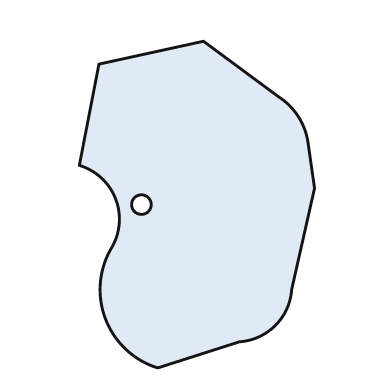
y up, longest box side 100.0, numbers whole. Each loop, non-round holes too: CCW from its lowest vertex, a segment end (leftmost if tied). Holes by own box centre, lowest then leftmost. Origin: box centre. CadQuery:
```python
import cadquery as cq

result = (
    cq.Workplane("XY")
    .moveTo(-12.0, -50.0)
    .lineTo(13.0, -42.0)
    .threePointArc((24.0, -37.0), (29.0, -26.0))
    .lineTo(36.0, 5.0)
    .lineTo(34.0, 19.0)
    .threePointArc((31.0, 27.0), (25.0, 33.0))
    .lineTo(2.0, 50.0)
    .lineTo(-30.0, 43.0)
    .lineTo(-36.0, 12.0)
    .threePointArc((-25.0, 2.0), (-26.0, -13.0))
    .threePointArc((-28.0, -35.0), (-12.0, -50.0))
    .close()
    .moveTo(-17.0, 0.0)
    .circle(3.0)
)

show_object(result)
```